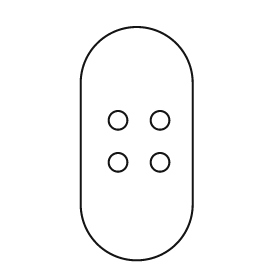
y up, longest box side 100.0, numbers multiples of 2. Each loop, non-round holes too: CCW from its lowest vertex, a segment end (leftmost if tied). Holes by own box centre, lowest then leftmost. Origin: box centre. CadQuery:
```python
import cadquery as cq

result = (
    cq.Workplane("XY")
    .moveTo(-24.0, -26.0)
    .threePointArc((0.0, -50.0), (24.0, -26.0))
    .lineTo(24.0, 26.0)
    .threePointArc((0.0, 50.0), (-24.0, 26.0))
    .close()
    .moveTo(-8.0, -8.0)
    .circle(4.0)
    .moveTo(10.0, -8.0)
    .circle(4.0)
    .moveTo(-8.0, 10.0)
    .circle(4.0)
    .moveTo(10.0, 10.0)
    .circle(4.0)
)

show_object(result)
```